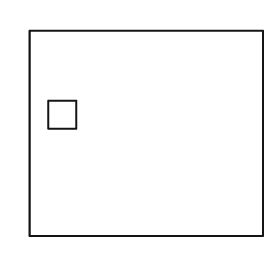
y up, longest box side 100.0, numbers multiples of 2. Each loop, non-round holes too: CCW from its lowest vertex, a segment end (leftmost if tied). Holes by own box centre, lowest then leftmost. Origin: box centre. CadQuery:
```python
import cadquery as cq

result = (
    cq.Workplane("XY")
    .moveTo(-50.0, -44.0)
    .lineTo(50.0, -44.0)
    .lineTo(50.0, 44.0)
    .lineTo(-50.0, 44.0)
    .close()
    .moveTo(-42.0, 2.0)
    .lineTo(-30.0, 2.0)
    .lineTo(-30.0, 14.0)
    .lineTo(-42.0, 14.0)
    .close()
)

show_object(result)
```